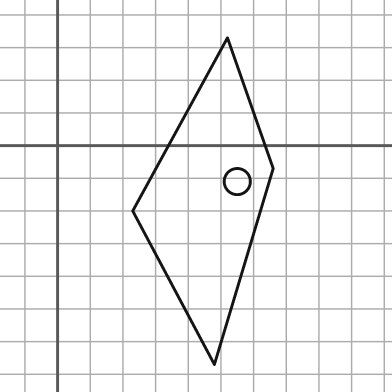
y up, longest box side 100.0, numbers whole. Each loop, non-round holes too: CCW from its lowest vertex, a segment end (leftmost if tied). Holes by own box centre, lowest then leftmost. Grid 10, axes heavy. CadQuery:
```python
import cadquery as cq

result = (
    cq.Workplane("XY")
    .moveTo(48.0, -67.0)
    .lineTo(66.0, -7.0)
    .lineTo(52.0, 33.0)
    .lineTo(23.0, -20.0)
    .close()
    .moveTo(55.0, -11.0)
    .circle(4.0)
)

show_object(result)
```